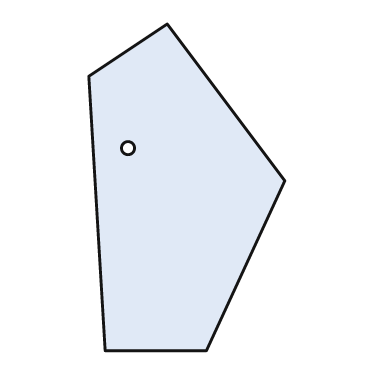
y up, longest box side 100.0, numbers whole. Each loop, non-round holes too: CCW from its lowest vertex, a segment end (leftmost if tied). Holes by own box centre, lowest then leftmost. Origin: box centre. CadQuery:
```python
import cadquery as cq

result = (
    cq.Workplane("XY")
    .moveTo(-25.0, -50.0)
    .lineTo(6.0, -50.0)
    .lineTo(30.0, 2.0)
    .lineTo(-6.0, 50.0)
    .lineTo(-30.0, 34.0)
    .close()
    .moveTo(-18.0, 12.0)
    .circle(2.0)
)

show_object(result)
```